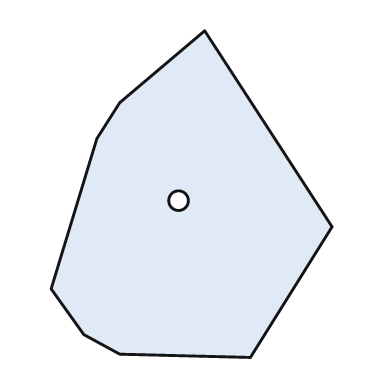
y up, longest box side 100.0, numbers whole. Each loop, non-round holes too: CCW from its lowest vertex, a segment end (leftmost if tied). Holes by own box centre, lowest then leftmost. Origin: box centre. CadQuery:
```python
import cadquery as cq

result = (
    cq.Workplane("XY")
    .moveTo(18.0, -50.0)
    .lineTo(43.0, -10.0)
    .lineTo(4.0, 50.0)
    .lineTo(-22.0, 28.0)
    .lineTo(-29.0, 17.0)
    .lineTo(-43.0, -29.0)
    .lineTo(-33.0, -43.0)
    .lineTo(-22.0, -49.0)
    .close()
    .moveTo(-4.0, -2.0)
    .circle(3.0)
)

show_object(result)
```